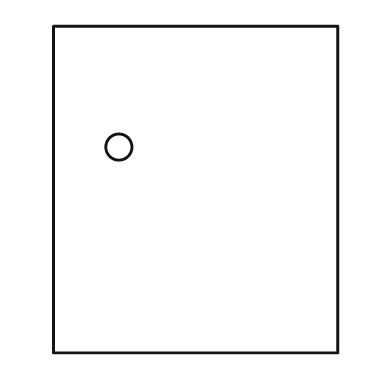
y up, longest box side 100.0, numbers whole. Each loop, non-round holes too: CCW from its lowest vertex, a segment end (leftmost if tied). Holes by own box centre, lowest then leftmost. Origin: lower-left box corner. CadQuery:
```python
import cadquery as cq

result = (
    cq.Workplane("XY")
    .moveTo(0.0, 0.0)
    .lineTo(87.0, 0.0)
    .lineTo(87.0, 100.0)
    .lineTo(0.0, 100.0)
    .close()
    .moveTo(20.0, 63.0)
    .circle(4.0)
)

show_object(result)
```